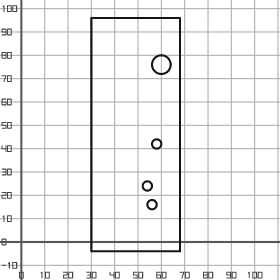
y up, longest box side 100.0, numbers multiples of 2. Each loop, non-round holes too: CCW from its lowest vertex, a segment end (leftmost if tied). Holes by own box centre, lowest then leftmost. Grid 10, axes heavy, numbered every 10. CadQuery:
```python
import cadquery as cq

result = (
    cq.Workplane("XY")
    .moveTo(30.0, -4.0)
    .lineTo(68.0, -4.0)
    .lineTo(68.0, 96.0)
    .lineTo(30.0, 96.0)
    .close()
    .moveTo(56.0, 16.0)
    .circle(2.0)
    .moveTo(54.0, 24.0)
    .circle(2.0)
    .moveTo(58.0, 42.0)
    .circle(2.0)
    .moveTo(60.0, 76.0)
    .circle(4.0)
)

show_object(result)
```